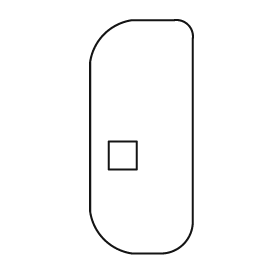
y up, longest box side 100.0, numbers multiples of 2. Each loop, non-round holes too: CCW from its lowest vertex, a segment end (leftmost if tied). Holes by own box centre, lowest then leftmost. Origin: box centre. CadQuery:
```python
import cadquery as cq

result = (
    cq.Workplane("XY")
    .moveTo(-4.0, -50.0)
    .lineTo(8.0, -50.0)
    .threePointArc((18.0, -46.0), (22.0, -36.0))
    .lineTo(22.0, 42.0)
    .threePointArc((20.0, 48.0), (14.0, 50.0))
    .lineTo(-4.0, 50.0)
    .threePointArc((-16.0, 44.0), (-22.0, 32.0))
    .lineTo(-22.0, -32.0)
    .threePointArc((-16.0, -44.0), (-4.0, -50.0))
    .close()
    .moveTo(-14.0, -14.0)
    .lineTo(-2.0, -14.0)
    .lineTo(-2.0, -2.0)
    .lineTo(-14.0, -2.0)
    .close()
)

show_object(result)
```